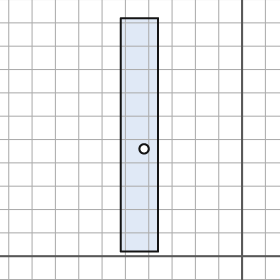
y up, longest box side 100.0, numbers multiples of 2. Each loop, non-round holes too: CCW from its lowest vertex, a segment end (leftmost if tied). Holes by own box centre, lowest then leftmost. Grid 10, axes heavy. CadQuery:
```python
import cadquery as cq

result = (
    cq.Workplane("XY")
    .moveTo(-52.0, 2.0)
    .lineTo(-36.0, 2.0)
    .lineTo(-36.0, 102.0)
    .lineTo(-52.0, 102.0)
    .close()
    .moveTo(-42.0, 46.0)
    .circle(2.0)
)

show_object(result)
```